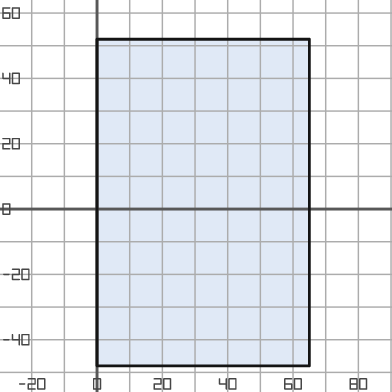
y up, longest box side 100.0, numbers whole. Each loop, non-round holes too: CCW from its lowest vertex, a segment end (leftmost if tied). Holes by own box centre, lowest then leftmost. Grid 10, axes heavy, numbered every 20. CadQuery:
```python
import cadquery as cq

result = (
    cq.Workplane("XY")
    .moveTo(0.0, -48.0)
    .lineTo(65.0, -48.0)
    .lineTo(65.0, 52.0)
    .lineTo(0.0, 52.0)
    .close()
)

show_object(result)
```